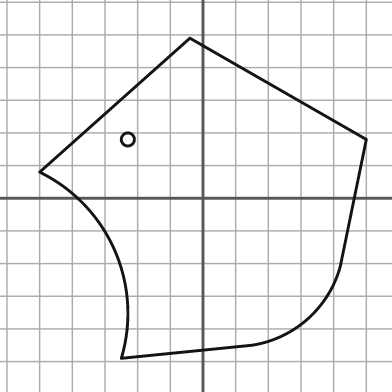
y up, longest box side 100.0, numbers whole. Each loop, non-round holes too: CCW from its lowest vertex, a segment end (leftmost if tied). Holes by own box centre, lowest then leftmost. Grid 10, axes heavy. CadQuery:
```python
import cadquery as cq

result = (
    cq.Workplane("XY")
    .moveTo(-25.0, -49.0)
    .lineTo(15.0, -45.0)
    .threePointArc((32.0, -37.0), (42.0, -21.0))
    .lineTo(50.0, 18.0)
    .lineTo(-4.0, 49.0)
    .lineTo(-50.0, 8.0)
    .threePointArc((-27.0, -16.0), (-25.0, -49.0))
    .close()
    .moveTo(-23.0, 18.0)
    .circle(2.0)
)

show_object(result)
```